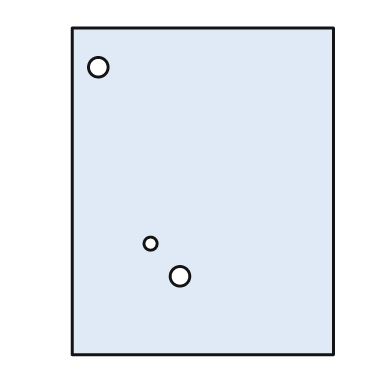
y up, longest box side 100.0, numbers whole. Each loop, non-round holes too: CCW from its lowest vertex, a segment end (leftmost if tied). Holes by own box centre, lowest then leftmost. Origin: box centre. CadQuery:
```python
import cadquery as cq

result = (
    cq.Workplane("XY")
    .moveTo(-40.0, -50.0)
    .lineTo(40.0, -50.0)
    .lineTo(40.0, 50.0)
    .lineTo(-40.0, 50.0)
    .close()
    .moveTo(-7.0, -26.0)
    .circle(3.0)
    .moveTo(-16.0, -16.0)
    .circle(2.0)
    .moveTo(-32.0, 38.0)
    .circle(3.0)
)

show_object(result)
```